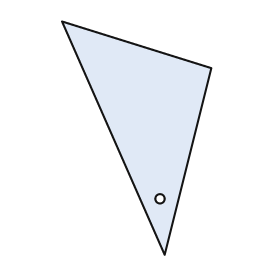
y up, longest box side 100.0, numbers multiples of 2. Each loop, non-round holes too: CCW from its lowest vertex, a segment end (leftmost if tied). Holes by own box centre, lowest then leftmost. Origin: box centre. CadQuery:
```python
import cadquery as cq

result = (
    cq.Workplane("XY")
    .moveTo(12.0, -50.0)
    .lineTo(32.0, 30.0)
    .lineTo(-32.0, 50.0)
    .close()
    .moveTo(10.0, -26.0)
    .circle(2.0)
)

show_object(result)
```